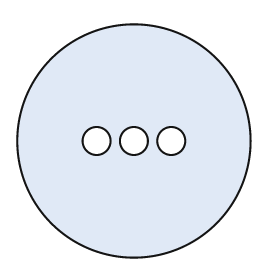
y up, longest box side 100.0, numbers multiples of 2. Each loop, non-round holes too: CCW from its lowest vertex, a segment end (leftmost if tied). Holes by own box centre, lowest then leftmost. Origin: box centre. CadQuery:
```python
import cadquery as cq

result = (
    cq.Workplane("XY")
    .moveTo(0.0, 0.0)
    .circle(50.0)
    .moveTo(-16.0, 0.0)
    .circle(6.0)
    .moveTo(0.0, 0.0)
    .circle(6.0)
    .moveTo(16.0, 0.0)
    .circle(6.0)
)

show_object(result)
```